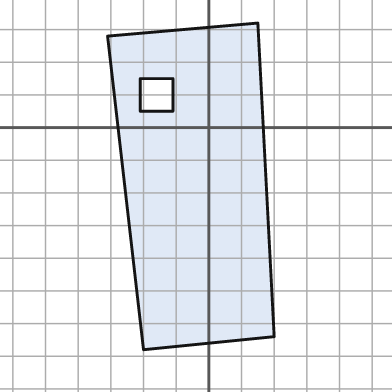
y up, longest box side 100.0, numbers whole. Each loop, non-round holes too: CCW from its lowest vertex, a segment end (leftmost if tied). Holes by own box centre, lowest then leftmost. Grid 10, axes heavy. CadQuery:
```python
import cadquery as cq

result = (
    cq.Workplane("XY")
    .moveTo(-20.0, -68.0)
    .lineTo(20.0, -64.0)
    .lineTo(15.0, 32.0)
    .lineTo(-31.0, 28.0)
    .close()
    .moveTo(-21.0, 5.0)
    .lineTo(-11.0, 5.0)
    .lineTo(-11.0, 15.0)
    .lineTo(-21.0, 15.0)
    .close()
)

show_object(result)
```